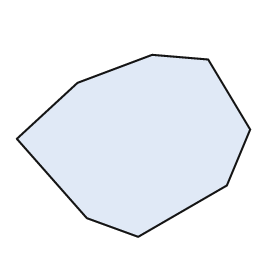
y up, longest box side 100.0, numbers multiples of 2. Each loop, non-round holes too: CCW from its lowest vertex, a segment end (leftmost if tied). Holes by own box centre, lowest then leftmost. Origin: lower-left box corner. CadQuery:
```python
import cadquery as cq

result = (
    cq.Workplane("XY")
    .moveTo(52.0, 0.0)
    .lineTo(90.0, 22.0)
    .lineTo(100.0, 46.0)
    .lineTo(82.0, 76.0)
    .lineTo(58.0, 78.0)
    .lineTo(26.0, 66.0)
    .lineTo(0.0, 42.0)
    .lineTo(30.0, 8.0)
    .close()
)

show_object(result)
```